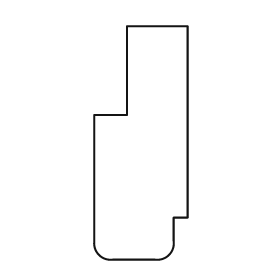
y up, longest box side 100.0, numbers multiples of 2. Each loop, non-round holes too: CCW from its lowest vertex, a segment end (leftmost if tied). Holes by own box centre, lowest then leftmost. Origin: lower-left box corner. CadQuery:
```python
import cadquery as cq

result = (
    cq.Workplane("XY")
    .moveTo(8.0, 0.0)
    .lineTo(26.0, 0.0)
    .threePointArc((32.0, 2.0), (34.0, 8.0))
    .lineTo(34.0, 18.0)
    .lineTo(40.0, 18.0)
    .lineTo(40.0, 100.0)
    .lineTo(14.0, 100.0)
    .lineTo(14.0, 62.0)
    .lineTo(0.0, 62.0)
    .lineTo(0.0, 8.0)
    .threePointArc((2.0, 2.0), (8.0, 0.0))
    .close()
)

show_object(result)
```